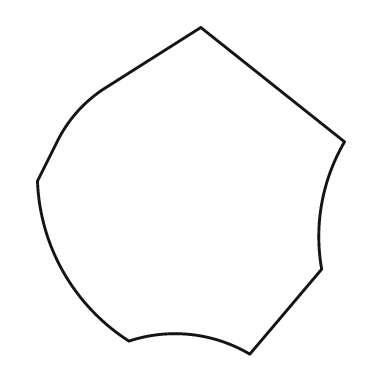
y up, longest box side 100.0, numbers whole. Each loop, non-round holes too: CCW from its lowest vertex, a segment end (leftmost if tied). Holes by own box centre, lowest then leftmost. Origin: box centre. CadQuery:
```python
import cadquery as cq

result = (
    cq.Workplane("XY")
    .moveTo(18.0, -50.0)
    .lineTo(40.0, -24.0)
    .threePointArc((40.0, -4.0), (47.0, 15.0))
    .lineTo(3.0, 50.0)
    .lineTo(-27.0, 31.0)
    .threePointArc((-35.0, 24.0), (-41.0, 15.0))
    .lineTo(-47.0, 3.0)
    .threePointArc((-39.0, -25.0), (-19.0, -46.0))
    .threePointArc((0.0, -44.0), (18.0, -50.0))
    .close()
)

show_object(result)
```